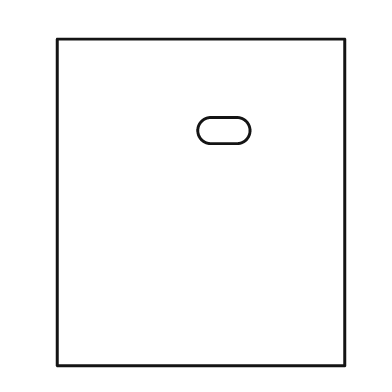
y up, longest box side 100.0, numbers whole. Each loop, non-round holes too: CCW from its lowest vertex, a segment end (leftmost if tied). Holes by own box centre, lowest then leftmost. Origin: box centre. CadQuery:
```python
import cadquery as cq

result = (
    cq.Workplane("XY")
    .moveTo(-44.0, -50.0)
    .lineTo(44.0, -50.0)
    .lineTo(44.0, 50.0)
    .lineTo(-44.0, 50.0)
    .close()
    .moveTo(3.0, 18.0)
    .lineTo(11.0, 18.0)
    .threePointArc((15.0, 22.0), (11.0, 26.0))
    .lineTo(3.0, 26.0)
    .threePointArc((-1.0, 22.0), (3.0, 18.0))
    .close()
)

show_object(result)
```